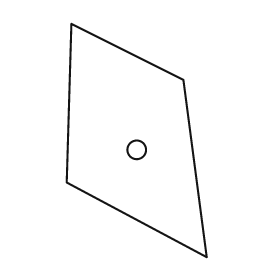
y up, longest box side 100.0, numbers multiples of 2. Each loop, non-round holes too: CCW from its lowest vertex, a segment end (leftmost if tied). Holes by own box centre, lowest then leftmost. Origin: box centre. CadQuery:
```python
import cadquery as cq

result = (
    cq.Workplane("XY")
    .moveTo(30.0, -50.0)
    .lineTo(20.0, 26.0)
    .lineTo(-28.0, 50.0)
    .lineTo(-30.0, -18.0)
    .close()
    .moveTo(0.0, -4.0)
    .circle(4.0)
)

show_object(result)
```